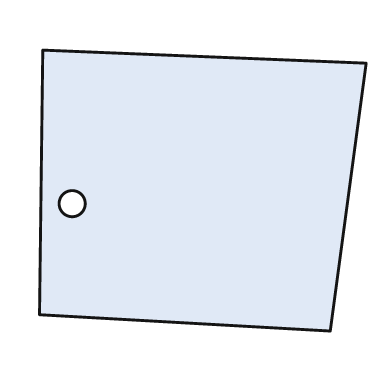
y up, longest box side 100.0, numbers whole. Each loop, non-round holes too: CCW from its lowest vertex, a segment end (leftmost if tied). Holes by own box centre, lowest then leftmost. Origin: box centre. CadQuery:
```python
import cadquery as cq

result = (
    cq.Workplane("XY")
    .moveTo(39.0, -43.0)
    .lineTo(50.0, 39.0)
    .lineTo(-49.0, 43.0)
    .lineTo(-50.0, -38.0)
    .close()
    .moveTo(-40.0, -4.0)
    .circle(4.0)
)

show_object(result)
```